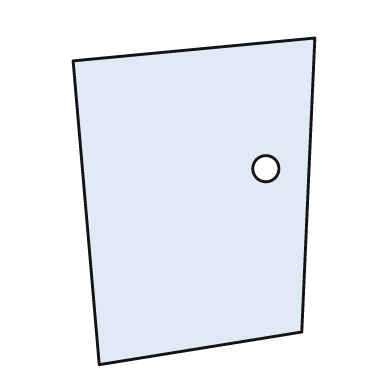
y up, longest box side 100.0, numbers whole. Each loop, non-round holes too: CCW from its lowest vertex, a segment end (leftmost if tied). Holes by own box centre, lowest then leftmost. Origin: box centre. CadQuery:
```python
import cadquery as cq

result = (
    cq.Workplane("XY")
    .moveTo(-29.0, -50.0)
    .lineTo(33.0, -40.0)
    .lineTo(37.0, 50.0)
    .lineTo(-37.0, 43.0)
    .close()
    .moveTo(22.0, 10.0)
    .circle(4.0)
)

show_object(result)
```